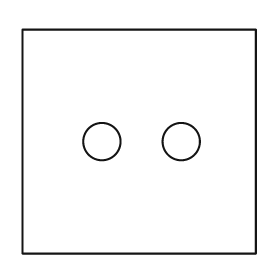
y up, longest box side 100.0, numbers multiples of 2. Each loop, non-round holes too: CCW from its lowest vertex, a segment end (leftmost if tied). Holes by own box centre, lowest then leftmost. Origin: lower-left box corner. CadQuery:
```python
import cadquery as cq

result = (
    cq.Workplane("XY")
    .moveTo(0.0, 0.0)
    .lineTo(100.0, 0.0)
    .lineTo(100.0, 96.0)
    .lineTo(0.0, 96.0)
    .close()
    .moveTo(34.0, 48.0)
    .circle(8.0)
    .moveTo(68.0, 48.0)
    .circle(8.0)
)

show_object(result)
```